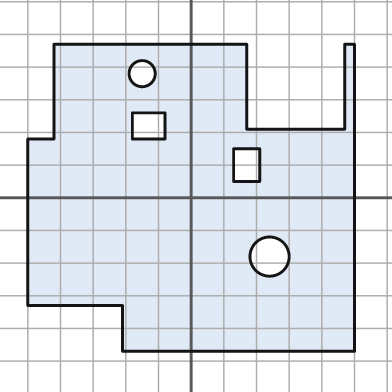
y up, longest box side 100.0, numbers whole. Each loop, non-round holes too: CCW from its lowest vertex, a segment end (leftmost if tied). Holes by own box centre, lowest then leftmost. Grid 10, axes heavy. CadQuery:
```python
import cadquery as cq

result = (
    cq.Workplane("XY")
    .moveTo(-21.0, -47.0)
    .lineTo(50.0, -47.0)
    .lineTo(50.0, 47.0)
    .lineTo(47.0, 47.0)
    .lineTo(47.0, 21.0)
    .lineTo(17.0, 21.0)
    .lineTo(17.0, 47.0)
    .lineTo(-42.0, 47.0)
    .lineTo(-42.0, 18.0)
    .lineTo(-50.0, 18.0)
    .lineTo(-50.0, -33.0)
    .lineTo(-21.0, -33.0)
    .close()
    .moveTo(24.0, -18.0)
    .circle(6.0)
    .moveTo(13.0, 5.0)
    .lineTo(21.0, 5.0)
    .lineTo(21.0, 15.0)
    .lineTo(13.0, 15.0)
    .close()
    .moveTo(-18.0, 18.0)
    .lineTo(-8.0, 18.0)
    .lineTo(-8.0, 26.0)
    .lineTo(-18.0, 26.0)
    .close()
    .moveTo(-15.0, 38.0)
    .circle(4.0)
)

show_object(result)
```